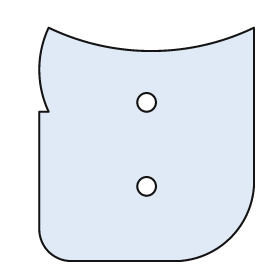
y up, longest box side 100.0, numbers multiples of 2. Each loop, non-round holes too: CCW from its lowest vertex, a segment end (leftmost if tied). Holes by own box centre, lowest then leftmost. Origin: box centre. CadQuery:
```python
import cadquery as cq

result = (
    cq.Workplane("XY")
    .moveTo(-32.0, -50.0)
    .lineTo(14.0, -50.0)
    .threePointArc((36.0, -40.0), (46.0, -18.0))
    .lineTo(46.0, 50.0)
    .threePointArc((2.0, 40.0), (-42.0, 50.0))
    .threePointArc((-46.0, 32.0), (-42.0, 14.0))
    .lineTo(-46.0, 14.0)
    .lineTo(-46.0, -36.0)
    .threePointArc((-42.0, -46.0), (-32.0, -50.0))
    .close()
    .moveTo(0.0, -18.0)
    .circle(4.0)
    .moveTo(0.0, 18.0)
    .circle(4.0)
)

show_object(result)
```